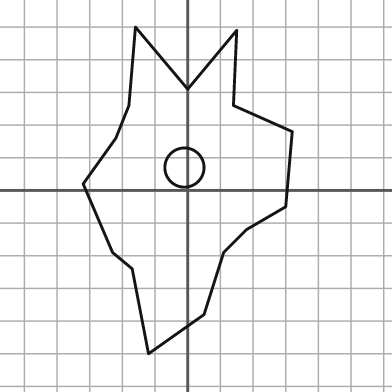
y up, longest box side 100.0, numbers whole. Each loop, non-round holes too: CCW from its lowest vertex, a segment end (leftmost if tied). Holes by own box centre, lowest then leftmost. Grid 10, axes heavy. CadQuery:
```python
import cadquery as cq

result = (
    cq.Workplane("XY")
    .moveTo(-12.0, -50.0)
    .lineTo(5.0, -38.0)
    .lineTo(11.0, -19.0)
    .lineTo(18.0, -12.0)
    .lineTo(30.0, -5.0)
    .lineTo(32.0, 18.0)
    .lineTo(14.0, 26.0)
    .lineTo(15.0, 49.0)
    .lineTo(0.0, 31.0)
    .lineTo(-16.0, 50.0)
    .lineTo(-18.0, 26.0)
    .lineTo(-22.0, 16.0)
    .lineTo(-32.0, 2.0)
    .lineTo(-23.0, -19.0)
    .lineTo(-17.0, -24.0)
    .close()
    .moveTo(-1.0, 7.0)
    .circle(6.0)
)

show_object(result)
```